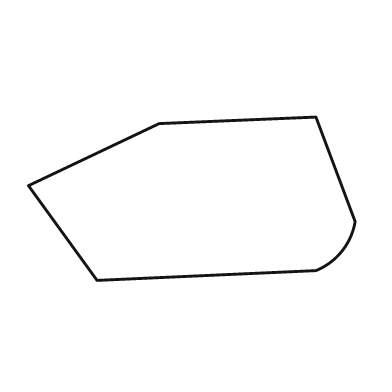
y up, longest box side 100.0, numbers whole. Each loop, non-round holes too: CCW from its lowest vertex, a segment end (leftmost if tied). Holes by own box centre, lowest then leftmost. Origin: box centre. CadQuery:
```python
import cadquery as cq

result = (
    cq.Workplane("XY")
    .moveTo(-29.0, -25.0)
    .lineTo(38.0, -22.0)
    .threePointArc((46.0, -16.0), (50.0, -7.0))
    .lineTo(38.0, 25.0)
    .lineTo(-10.0, 23.0)
    .lineTo(-50.0, 4.0)
    .close()
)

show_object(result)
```